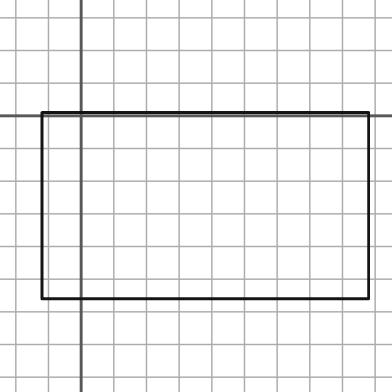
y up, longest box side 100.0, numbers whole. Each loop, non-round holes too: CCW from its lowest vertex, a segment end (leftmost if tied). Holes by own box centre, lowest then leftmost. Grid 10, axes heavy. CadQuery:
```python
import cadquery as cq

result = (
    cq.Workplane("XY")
    .moveTo(-12.0, -56.0)
    .lineTo(88.0, -56.0)
    .lineTo(88.0, 1.0)
    .lineTo(-12.0, 1.0)
    .close()
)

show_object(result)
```